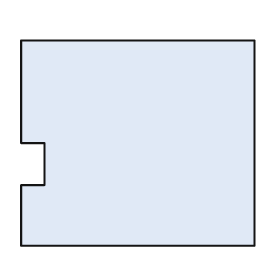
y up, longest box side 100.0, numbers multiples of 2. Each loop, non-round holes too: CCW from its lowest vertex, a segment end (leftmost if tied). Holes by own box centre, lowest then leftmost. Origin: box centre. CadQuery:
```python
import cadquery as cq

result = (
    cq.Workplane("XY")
    .moveTo(-50.0, -44.0)
    .lineTo(50.0, -44.0)
    .lineTo(50.0, 44.0)
    .lineTo(-50.0, 44.0)
    .lineTo(-50.0, 0.0)
    .lineTo(-40.0, 0.0)
    .lineTo(-40.0, -18.0)
    .lineTo(-50.0, -18.0)
    .close()
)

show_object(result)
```